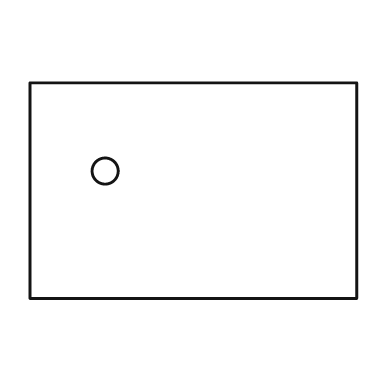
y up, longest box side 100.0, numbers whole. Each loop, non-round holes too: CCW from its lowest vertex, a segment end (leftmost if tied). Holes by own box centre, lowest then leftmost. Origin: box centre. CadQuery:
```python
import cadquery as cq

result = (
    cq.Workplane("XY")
    .moveTo(-50.0, -33.0)
    .lineTo(50.0, -33.0)
    .lineTo(50.0, 33.0)
    .lineTo(-50.0, 33.0)
    .close()
    .moveTo(-27.0, 6.0)
    .circle(4.0)
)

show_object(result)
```